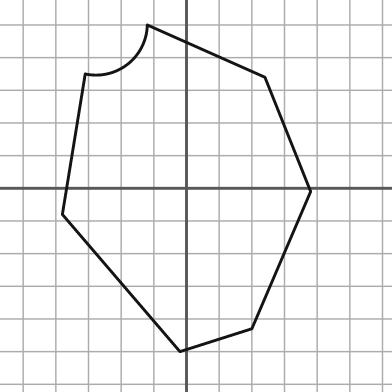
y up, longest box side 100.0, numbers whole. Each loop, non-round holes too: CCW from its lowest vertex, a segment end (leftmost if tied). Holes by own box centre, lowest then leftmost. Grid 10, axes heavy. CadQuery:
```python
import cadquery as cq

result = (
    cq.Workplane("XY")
    .moveTo(-2.0, -50.0)
    .lineTo(20.0, -43.0)
    .lineTo(38.0, -1.0)
    .lineTo(24.0, 34.0)
    .lineTo(-12.0, 50.0)
    .threePointArc((-18.0, 38.0), (-31.0, 35.0))
    .lineTo(-38.0, -8.0)
    .close()
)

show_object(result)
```